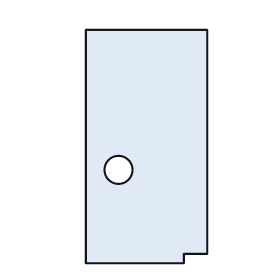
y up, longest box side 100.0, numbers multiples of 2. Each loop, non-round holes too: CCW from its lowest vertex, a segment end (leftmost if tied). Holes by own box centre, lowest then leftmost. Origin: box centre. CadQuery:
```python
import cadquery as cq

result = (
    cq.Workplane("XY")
    .moveTo(-26.0, -50.0)
    .lineTo(16.0, -50.0)
    .lineTo(16.0, -46.0)
    .lineTo(26.0, -46.0)
    .lineTo(26.0, 50.0)
    .lineTo(-26.0, 50.0)
    .close()
    .moveTo(-12.0, -10.0)
    .circle(6.0)
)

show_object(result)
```